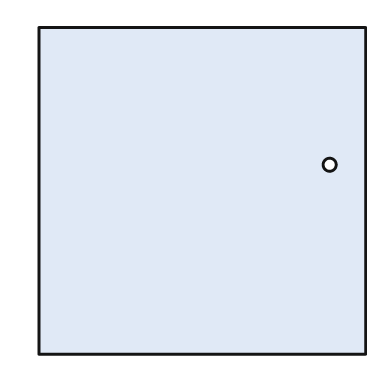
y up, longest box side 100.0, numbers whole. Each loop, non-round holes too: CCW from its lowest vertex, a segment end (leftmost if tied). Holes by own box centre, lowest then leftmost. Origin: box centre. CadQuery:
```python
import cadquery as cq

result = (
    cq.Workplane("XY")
    .moveTo(-50.0, -50.0)
    .lineTo(50.0, -50.0)
    .lineTo(50.0, 50.0)
    .lineTo(-50.0, 50.0)
    .close()
    .moveTo(39.0, 8.0)
    .circle(2.0)
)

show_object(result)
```